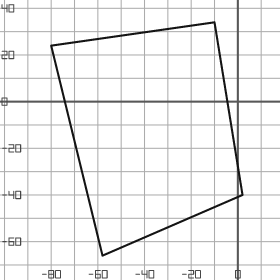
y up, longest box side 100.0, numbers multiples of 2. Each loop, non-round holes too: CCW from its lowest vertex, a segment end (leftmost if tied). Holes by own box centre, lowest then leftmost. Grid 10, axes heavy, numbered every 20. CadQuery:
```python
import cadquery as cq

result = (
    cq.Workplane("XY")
    .moveTo(-58.0, -66.0)
    .lineTo(2.0, -40.0)
    .lineTo(-10.0, 34.0)
    .lineTo(-80.0, 24.0)
    .close()
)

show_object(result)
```